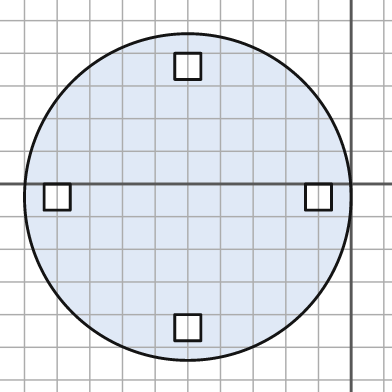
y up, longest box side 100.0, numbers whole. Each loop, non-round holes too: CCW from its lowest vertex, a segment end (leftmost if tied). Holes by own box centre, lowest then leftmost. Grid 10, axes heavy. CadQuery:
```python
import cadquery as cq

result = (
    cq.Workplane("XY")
    .moveTo(-50.0, -4.0)
    .circle(50.0)
    .moveTo(-54.0, -48.0)
    .lineTo(-46.0, -48.0)
    .lineTo(-46.0, -40.0)
    .lineTo(-54.0, -40.0)
    .close()
    .moveTo(-94.0, -8.0)
    .lineTo(-86.0, -8.0)
    .lineTo(-86.0, 0.0)
    .lineTo(-94.0, 0.0)
    .close()
    .moveTo(-14.0, -8.0)
    .lineTo(-6.0, -8.0)
    .lineTo(-6.0, 0.0)
    .lineTo(-14.0, 0.0)
    .close()
    .moveTo(-54.0, 32.0)
    .lineTo(-46.0, 32.0)
    .lineTo(-46.0, 40.0)
    .lineTo(-54.0, 40.0)
    .close()
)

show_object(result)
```